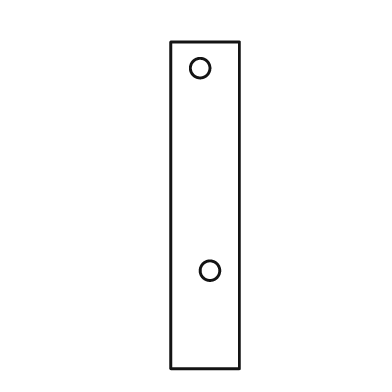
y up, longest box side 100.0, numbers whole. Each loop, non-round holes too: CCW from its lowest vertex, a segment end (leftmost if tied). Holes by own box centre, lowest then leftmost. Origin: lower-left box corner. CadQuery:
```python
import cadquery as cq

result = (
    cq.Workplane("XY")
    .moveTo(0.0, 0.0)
    .lineTo(21.0, 0.0)
    .lineTo(21.0, 100.0)
    .lineTo(0.0, 100.0)
    .close()
    .moveTo(12.0, 30.0)
    .circle(3.0)
    .moveTo(9.0, 92.0)
    .circle(3.0)
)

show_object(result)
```